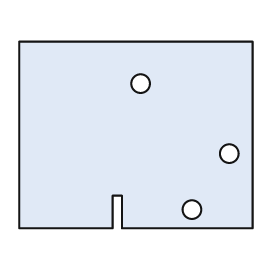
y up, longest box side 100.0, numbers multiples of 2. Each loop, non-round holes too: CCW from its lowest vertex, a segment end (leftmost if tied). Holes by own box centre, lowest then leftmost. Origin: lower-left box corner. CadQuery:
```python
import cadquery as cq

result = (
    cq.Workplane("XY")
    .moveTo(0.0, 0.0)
    .lineTo(40.0, 0.0)
    .lineTo(40.0, 14.0)
    .lineTo(44.0, 14.0)
    .lineTo(44.0, 0.0)
    .lineTo(100.0, 0.0)
    .lineTo(100.0, 80.0)
    .lineTo(0.0, 80.0)
    .close()
    .moveTo(74.0, 8.0)
    .circle(4.0)
    .moveTo(90.0, 32.0)
    .circle(4.0)
    .moveTo(52.0, 62.0)
    .circle(4.0)
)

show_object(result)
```